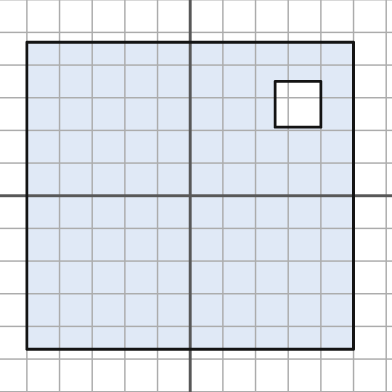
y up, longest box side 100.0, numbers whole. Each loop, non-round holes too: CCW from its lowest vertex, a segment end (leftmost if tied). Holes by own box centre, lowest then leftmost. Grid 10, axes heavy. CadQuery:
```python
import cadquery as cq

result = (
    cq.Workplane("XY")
    .moveTo(-50.0, -47.0)
    .lineTo(50.0, -47.0)
    .lineTo(50.0, 47.0)
    .lineTo(-50.0, 47.0)
    .close()
    .moveTo(26.0, 21.0)
    .lineTo(40.0, 21.0)
    .lineTo(40.0, 35.0)
    .lineTo(26.0, 35.0)
    .close()
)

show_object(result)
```